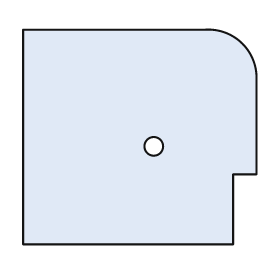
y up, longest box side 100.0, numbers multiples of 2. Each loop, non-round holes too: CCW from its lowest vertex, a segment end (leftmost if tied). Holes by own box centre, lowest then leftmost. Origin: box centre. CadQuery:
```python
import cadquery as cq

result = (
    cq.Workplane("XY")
    .moveTo(-50.0, -46.0)
    .lineTo(40.0, -46.0)
    .lineTo(40.0, -16.0)
    .lineTo(50.0, -16.0)
    .lineTo(50.0, 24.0)
    .threePointArc((44.0, 40.0), (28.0, 46.0))
    .lineTo(-50.0, 46.0)
    .close()
    .moveTo(6.0, -4.0)
    .circle(4.0)
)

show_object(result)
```